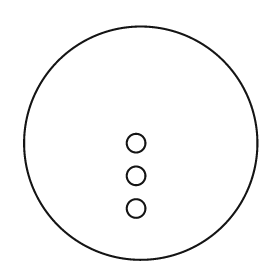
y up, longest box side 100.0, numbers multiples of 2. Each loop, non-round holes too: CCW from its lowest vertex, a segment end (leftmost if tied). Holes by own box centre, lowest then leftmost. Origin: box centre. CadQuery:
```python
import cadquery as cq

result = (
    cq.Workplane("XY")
    .moveTo(0.0, 0.0)
    .circle(50.0)
    .moveTo(-2.0, -28.0)
    .circle(4.0)
    .moveTo(-2.0, -14.0)
    .circle(4.0)
    .moveTo(-2.0, 0.0)
    .circle(4.0)
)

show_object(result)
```